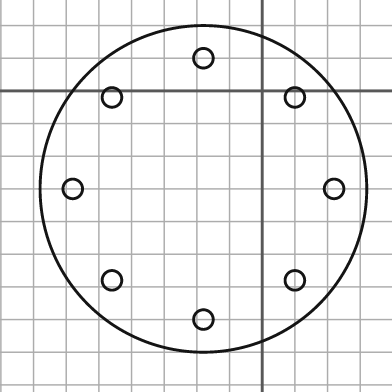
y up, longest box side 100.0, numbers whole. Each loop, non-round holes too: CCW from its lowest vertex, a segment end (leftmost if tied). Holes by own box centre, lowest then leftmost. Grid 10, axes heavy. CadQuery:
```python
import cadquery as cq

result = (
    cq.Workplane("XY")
    .moveTo(-18.0, -30.0)
    .circle(50.0)
    .moveTo(-18.0, -70.0)
    .circle(3.0)
    .moveTo(-46.0, -58.0)
    .circle(3.0)
    .moveTo(10.0, -58.0)
    .circle(3.0)
    .moveTo(-58.0, -30.0)
    .circle(3.0)
    .moveTo(22.0, -30.0)
    .circle(3.0)
    .moveTo(-46.0, -2.0)
    .circle(3.0)
    .moveTo(10.0, -2.0)
    .circle(3.0)
    .moveTo(-18.0, 10.0)
    .circle(3.0)
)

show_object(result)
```